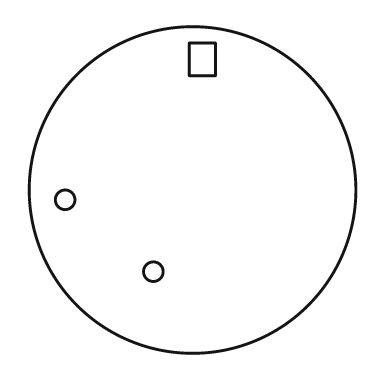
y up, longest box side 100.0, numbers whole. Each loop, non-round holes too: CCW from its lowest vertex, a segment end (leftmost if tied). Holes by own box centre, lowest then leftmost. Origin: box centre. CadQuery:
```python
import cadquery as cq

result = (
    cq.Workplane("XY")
    .moveTo(0.0, 0.0)
    .circle(50.0)
    .moveTo(-12.0, -25.0)
    .circle(3.0)
    .moveTo(-39.0, -3.0)
    .circle(3.0)
    .moveTo(-1.0, 35.0)
    .lineTo(7.0, 35.0)
    .lineTo(7.0, 45.0)
    .lineTo(-1.0, 45.0)
    .close()
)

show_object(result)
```